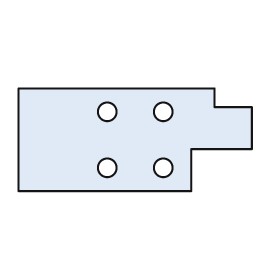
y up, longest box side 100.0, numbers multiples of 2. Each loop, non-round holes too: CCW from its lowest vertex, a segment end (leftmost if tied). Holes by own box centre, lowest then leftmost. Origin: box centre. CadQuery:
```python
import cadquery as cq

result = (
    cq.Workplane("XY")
    .moveTo(-50.0, -22.0)
    .lineTo(24.0, -22.0)
    .lineTo(24.0, -4.0)
    .lineTo(50.0, -4.0)
    .lineTo(50.0, 14.0)
    .lineTo(34.0, 14.0)
    .lineTo(34.0, 22.0)
    .lineTo(-50.0, 22.0)
    .close()
    .moveTo(-12.0, -12.0)
    .circle(4.0)
    .moveTo(12.0, -12.0)
    .circle(4.0)
    .moveTo(-12.0, 12.0)
    .circle(4.0)
    .moveTo(12.0, 12.0)
    .circle(4.0)
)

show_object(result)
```